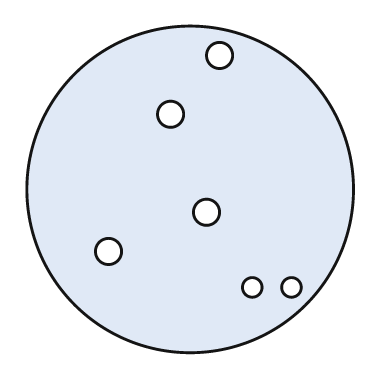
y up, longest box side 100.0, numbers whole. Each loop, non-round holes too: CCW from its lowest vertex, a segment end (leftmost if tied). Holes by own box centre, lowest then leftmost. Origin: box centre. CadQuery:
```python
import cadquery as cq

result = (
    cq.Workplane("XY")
    .moveTo(0.0, 0.0)
    .circle(50.0)
    .moveTo(19.0, -30.0)
    .circle(3.0)
    .moveTo(31.0, -30.0)
    .circle(3.0)
    .moveTo(-25.0, -19.0)
    .circle(4.0)
    .moveTo(5.0, -7.0)
    .circle(4.0)
    .moveTo(-6.0, 23.0)
    .circle(4.0)
    .moveTo(9.0, 41.0)
    .circle(4.0)
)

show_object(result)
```